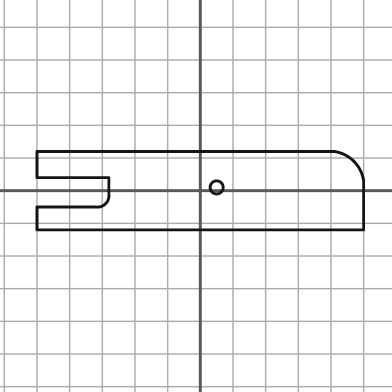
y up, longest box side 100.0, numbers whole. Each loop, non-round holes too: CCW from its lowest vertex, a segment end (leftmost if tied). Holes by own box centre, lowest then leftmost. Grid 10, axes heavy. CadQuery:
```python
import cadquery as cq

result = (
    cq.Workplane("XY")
    .moveTo(-50.0, -12.0)
    .lineTo(50.0, -12.0)
    .lineTo(50.0, 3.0)
    .threePointArc((47.0, 9.0), (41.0, 12.0))
    .lineTo(-50.0, 12.0)
    .lineTo(-50.0, 4.0)
    .lineTo(-28.0, 4.0)
    .lineTo(-28.0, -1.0)
    .threePointArc((-29.0, -4.0), (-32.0, -5.0))
    .lineTo(-50.0, -5.0)
    .close()
    .moveTo(5.0, 1.0)
    .circle(2.0)
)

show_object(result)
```